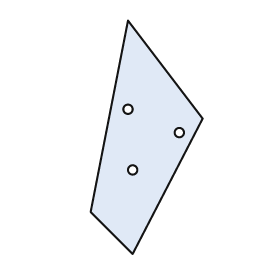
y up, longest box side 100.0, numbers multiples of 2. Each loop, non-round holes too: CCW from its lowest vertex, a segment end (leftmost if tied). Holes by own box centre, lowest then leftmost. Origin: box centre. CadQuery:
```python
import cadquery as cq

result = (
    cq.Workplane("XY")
    .moveTo(-6.0, -50.0)
    .lineTo(24.0, 8.0)
    .lineTo(-8.0, 50.0)
    .lineTo(-24.0, -32.0)
    .close()
    .moveTo(-6.0, -14.0)
    .circle(2.0)
    .moveTo(14.0, 2.0)
    .circle(2.0)
    .moveTo(-8.0, 12.0)
    .circle(2.0)
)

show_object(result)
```